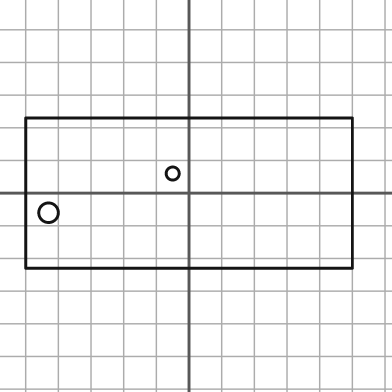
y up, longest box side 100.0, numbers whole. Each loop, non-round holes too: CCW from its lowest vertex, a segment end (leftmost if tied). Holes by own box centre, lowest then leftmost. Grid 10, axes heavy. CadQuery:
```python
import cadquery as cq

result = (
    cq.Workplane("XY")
    .moveTo(-50.0, -23.0)
    .lineTo(50.0, -23.0)
    .lineTo(50.0, 23.0)
    .lineTo(-50.0, 23.0)
    .close()
    .moveTo(-43.0, -6.0)
    .circle(3.0)
    .moveTo(-5.0, 6.0)
    .circle(2.0)
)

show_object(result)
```